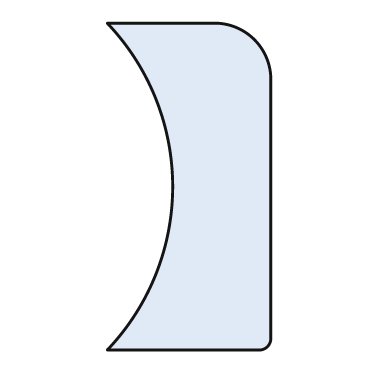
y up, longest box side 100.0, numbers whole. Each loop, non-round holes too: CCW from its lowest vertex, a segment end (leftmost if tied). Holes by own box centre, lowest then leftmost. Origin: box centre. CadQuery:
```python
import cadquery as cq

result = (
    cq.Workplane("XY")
    .moveTo(-25.0, -50.0)
    .lineTo(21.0, -50.0)
    .threePointArc((24.0, -49.0), (25.0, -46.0))
    .lineTo(25.0, 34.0)
    .threePointArc((20.0, 45.0), (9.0, 50.0))
    .lineTo(-25.0, 50.0)
    .threePointArc((-5.0, 0.0), (-25.0, -50.0))
    .close()
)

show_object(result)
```